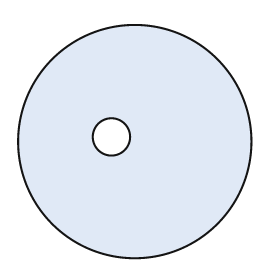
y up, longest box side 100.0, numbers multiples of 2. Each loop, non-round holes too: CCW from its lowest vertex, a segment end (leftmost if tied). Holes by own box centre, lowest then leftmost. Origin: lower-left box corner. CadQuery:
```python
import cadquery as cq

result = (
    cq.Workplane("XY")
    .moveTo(50.0, 50.0)
    .circle(50.0)
    .moveTo(40.0, 52.0)
    .circle(8.0)
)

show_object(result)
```